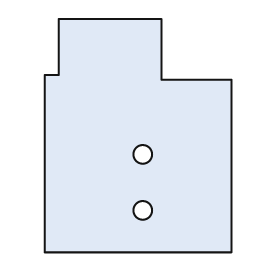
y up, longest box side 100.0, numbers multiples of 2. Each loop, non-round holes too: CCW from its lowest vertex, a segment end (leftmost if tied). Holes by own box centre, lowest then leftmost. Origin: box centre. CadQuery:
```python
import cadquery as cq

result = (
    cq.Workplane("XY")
    .moveTo(-40.0, -50.0)
    .lineTo(40.0, -50.0)
    .lineTo(40.0, 24.0)
    .lineTo(10.0, 24.0)
    .lineTo(10.0, 50.0)
    .lineTo(-34.0, 50.0)
    .lineTo(-34.0, 26.0)
    .lineTo(-40.0, 26.0)
    .close()
    .moveTo(2.0, -32.0)
    .circle(4.0)
    .moveTo(2.0, -8.0)
    .circle(4.0)
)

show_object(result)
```